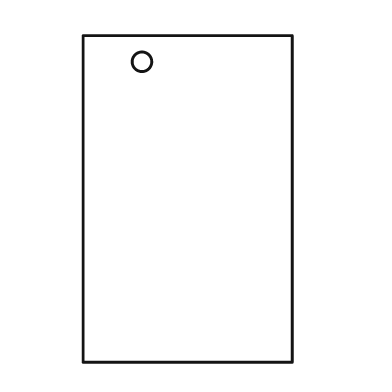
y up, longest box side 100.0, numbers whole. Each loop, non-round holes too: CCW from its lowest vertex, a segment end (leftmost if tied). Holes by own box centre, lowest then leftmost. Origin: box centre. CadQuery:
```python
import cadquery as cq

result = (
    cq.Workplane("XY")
    .moveTo(-32.0, -50.0)
    .lineTo(32.0, -50.0)
    .lineTo(32.0, 50.0)
    .lineTo(-32.0, 50.0)
    .close()
    .moveTo(-14.0, 42.0)
    .circle(3.0)
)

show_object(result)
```